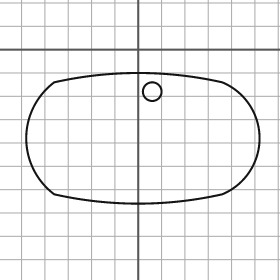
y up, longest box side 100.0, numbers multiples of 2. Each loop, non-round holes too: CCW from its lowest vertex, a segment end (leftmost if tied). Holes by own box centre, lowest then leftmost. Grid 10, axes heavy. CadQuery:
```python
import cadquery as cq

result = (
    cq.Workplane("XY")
    .moveTo(-36.0, -62.0)
    .threePointArc((0.0, -66.0), (36.0, -62.0))
    .threePointArc((52.0, -38.0), (36.0, -14.0))
    .threePointArc((0.0, -10.0), (-36.0, -14.0))
    .threePointArc((-48.0, -38.0), (-36.0, -62.0))
    .close()
    .moveTo(6.0, -18.0)
    .circle(4.0)
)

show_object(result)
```